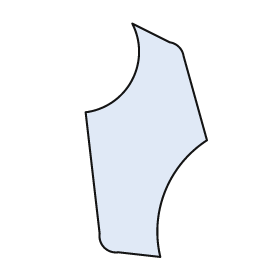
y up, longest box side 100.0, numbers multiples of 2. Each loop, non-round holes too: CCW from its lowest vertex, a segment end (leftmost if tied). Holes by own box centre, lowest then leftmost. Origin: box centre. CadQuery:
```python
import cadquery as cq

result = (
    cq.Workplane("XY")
    .moveTo(6.0, -50.0)
    .threePointArc((8.0, -22.0), (26.0, 0.0))
    .lineTo(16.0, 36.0)
    .threePointArc((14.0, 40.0), (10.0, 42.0))
    .lineTo(-6.0, 50.0)
    .threePointArc((-6.0, 26.0), (-26.0, 12.0))
    .lineTo(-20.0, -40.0)
    .threePointArc((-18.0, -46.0), (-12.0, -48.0))
    .close()
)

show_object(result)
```